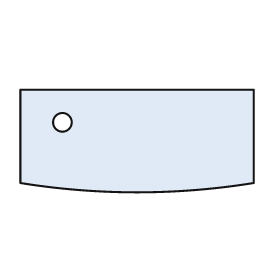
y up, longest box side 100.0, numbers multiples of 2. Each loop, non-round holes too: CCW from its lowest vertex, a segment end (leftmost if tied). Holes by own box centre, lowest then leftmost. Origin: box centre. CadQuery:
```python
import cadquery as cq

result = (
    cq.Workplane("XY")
    .moveTo(-50.0, -18.0)
    .threePointArc((0.0, -22.0), (50.0, -18.0))
    .lineTo(50.0, 22.0)
    .lineTo(-50.0, 22.0)
    .close()
    .moveTo(-32.0, 8.0)
    .circle(4.0)
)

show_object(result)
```